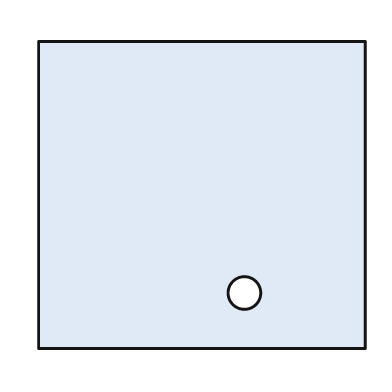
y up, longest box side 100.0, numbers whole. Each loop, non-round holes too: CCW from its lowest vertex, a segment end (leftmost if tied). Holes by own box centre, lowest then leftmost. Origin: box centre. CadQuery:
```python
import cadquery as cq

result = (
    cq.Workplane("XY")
    .moveTo(-50.0, -47.0)
    .lineTo(50.0, -47.0)
    .lineTo(50.0, 47.0)
    .lineTo(-50.0, 47.0)
    .close()
    .moveTo(13.0, -30.0)
    .circle(5.0)
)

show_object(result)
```